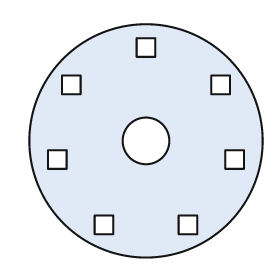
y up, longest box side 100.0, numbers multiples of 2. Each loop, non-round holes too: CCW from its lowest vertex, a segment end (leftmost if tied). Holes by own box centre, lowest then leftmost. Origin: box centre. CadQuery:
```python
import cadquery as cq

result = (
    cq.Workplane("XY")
    .moveTo(0.0, 0.0)
    .circle(50.0)
    .moveTo(-22.0, -40.0)
    .lineTo(-14.0, -40.0)
    .lineTo(-14.0, -32.0)
    .lineTo(-22.0, -32.0)
    .close()
    .moveTo(14.0, -40.0)
    .lineTo(22.0, -40.0)
    .lineTo(22.0, -32.0)
    .lineTo(14.0, -32.0)
    .close()
    .moveTo(-42.0, -12.0)
    .lineTo(-34.0, -12.0)
    .lineTo(-34.0, -4.0)
    .lineTo(-42.0, -4.0)
    .close()
    .moveTo(34.0, -12.0)
    .lineTo(42.0, -12.0)
    .lineTo(42.0, -4.0)
    .lineTo(34.0, -4.0)
    .close()
    .moveTo(0.0, 0.0)
    .circle(10.0)
    .moveTo(-36.0, 20.0)
    .lineTo(-28.0, 20.0)
    .lineTo(-28.0, 28.0)
    .lineTo(-36.0, 28.0)
    .close()
    .moveTo(28.0, 20.0)
    .lineTo(36.0, 20.0)
    .lineTo(36.0, 28.0)
    .lineTo(28.0, 28.0)
    .close()
    .moveTo(-4.0, 36.0)
    .lineTo(4.0, 36.0)
    .lineTo(4.0, 44.0)
    .lineTo(-4.0, 44.0)
    .close()
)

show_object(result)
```